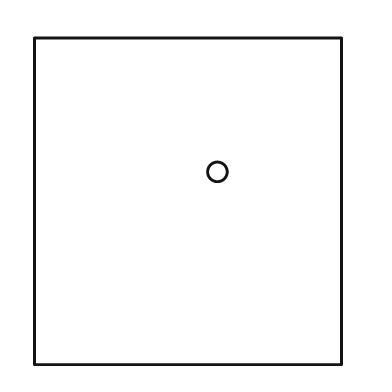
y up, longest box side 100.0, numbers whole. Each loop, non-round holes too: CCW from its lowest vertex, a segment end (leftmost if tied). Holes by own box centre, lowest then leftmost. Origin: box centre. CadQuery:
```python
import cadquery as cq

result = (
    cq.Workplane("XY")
    .moveTo(-47.0, -50.0)
    .lineTo(47.0, -50.0)
    .lineTo(47.0, 50.0)
    .lineTo(-47.0, 50.0)
    .close()
    .moveTo(9.0, 9.0)
    .circle(3.0)
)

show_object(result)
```